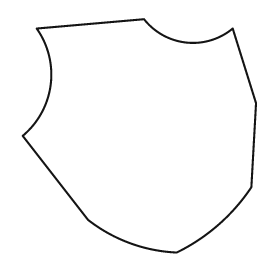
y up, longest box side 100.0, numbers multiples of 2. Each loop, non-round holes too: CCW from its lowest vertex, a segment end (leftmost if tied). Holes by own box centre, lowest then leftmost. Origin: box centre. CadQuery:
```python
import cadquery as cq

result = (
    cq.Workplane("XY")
    .moveTo(16.0, -50.0)
    .threePointArc((34.0, -38.0), (48.0, -22.0))
    .lineTo(50.0, 14.0)
    .lineTo(40.0, 46.0)
    .threePointArc((20.0, 40.0), (2.0, 50.0))
    .lineTo(-44.0, 46.0)
    .threePointArc((-38.0, 22.0), (-50.0, 0.0))
    .lineTo(-22.0, -36.0)
    .threePointArc((-4.0, -46.0), (16.0, -50.0))
    .close()
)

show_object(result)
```